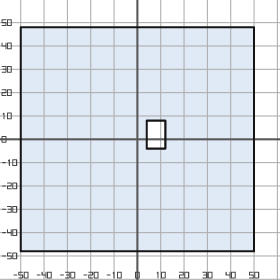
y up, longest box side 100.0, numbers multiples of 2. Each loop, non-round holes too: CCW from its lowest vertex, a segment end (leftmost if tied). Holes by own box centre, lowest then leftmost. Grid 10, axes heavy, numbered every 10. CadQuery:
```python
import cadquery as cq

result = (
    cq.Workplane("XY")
    .moveTo(-50.0, -48.0)
    .lineTo(50.0, -48.0)
    .lineTo(50.0, 48.0)
    .lineTo(-50.0, 48.0)
    .close()
    .moveTo(4.0, -4.0)
    .lineTo(12.0, -4.0)
    .lineTo(12.0, 8.0)
    .lineTo(4.0, 8.0)
    .close()
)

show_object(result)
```